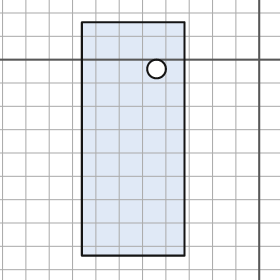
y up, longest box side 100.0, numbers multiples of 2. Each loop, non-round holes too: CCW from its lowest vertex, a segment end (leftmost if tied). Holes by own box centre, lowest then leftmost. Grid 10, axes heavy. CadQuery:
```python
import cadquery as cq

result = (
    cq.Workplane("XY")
    .moveTo(-76.0, -84.0)
    .lineTo(-32.0, -84.0)
    .lineTo(-32.0, 16.0)
    .lineTo(-76.0, 16.0)
    .close()
    .moveTo(-44.0, -4.0)
    .circle(4.0)
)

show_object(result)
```